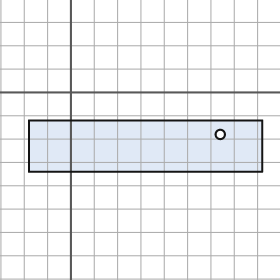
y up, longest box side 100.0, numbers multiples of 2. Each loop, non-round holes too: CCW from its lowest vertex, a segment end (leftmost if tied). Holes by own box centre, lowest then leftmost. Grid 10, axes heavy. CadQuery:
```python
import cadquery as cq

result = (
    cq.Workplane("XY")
    .moveTo(-18.0, -34.0)
    .lineTo(82.0, -34.0)
    .lineTo(82.0, -12.0)
    .lineTo(-18.0, -12.0)
    .close()
    .moveTo(64.0, -18.0)
    .circle(2.0)
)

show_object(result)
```